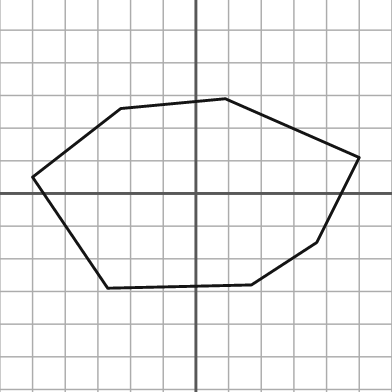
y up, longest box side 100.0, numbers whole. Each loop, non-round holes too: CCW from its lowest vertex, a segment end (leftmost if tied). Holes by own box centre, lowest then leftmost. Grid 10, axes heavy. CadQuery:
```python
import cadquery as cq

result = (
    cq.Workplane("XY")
    .moveTo(-27.0, -29.0)
    .lineTo(17.0, -28.0)
    .lineTo(37.0, -15.0)
    .lineTo(50.0, 11.0)
    .lineTo(9.0, 29.0)
    .lineTo(-23.0, 26.0)
    .lineTo(-50.0, 5.0)
    .close()
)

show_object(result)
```